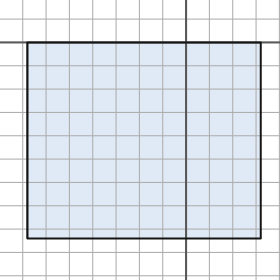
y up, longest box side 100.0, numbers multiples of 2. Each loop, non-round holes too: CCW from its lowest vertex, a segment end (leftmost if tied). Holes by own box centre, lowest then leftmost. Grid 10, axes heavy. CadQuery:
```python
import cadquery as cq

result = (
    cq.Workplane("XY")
    .moveTo(-68.0, -84.0)
    .lineTo(32.0, -84.0)
    .lineTo(32.0, 0.0)
    .lineTo(-68.0, 0.0)
    .close()
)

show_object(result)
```